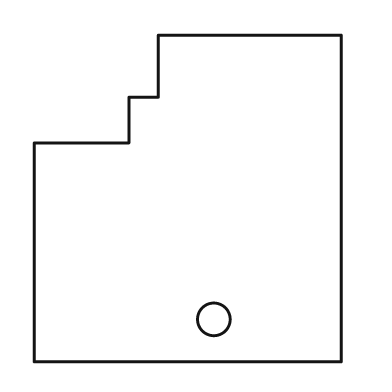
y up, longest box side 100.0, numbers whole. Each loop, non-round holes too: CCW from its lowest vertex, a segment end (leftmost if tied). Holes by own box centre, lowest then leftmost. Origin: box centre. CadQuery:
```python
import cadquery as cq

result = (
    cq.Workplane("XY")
    .moveTo(-47.0, -50.0)
    .lineTo(47.0, -50.0)
    .lineTo(47.0, 50.0)
    .lineTo(-9.0, 50.0)
    .lineTo(-9.0, 31.0)
    .lineTo(-18.0, 31.0)
    .lineTo(-18.0, 17.0)
    .lineTo(-47.0, 17.0)
    .close()
    .moveTo(8.0, -37.0)
    .circle(5.0)
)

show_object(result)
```